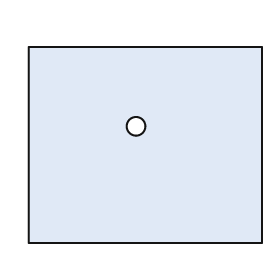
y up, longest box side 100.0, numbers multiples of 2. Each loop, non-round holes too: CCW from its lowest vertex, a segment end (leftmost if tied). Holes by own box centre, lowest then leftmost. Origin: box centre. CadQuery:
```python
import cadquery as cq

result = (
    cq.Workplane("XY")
    .moveTo(-50.0, -42.0)
    .lineTo(50.0, -42.0)
    .lineTo(50.0, 42.0)
    .lineTo(-50.0, 42.0)
    .close()
    .moveTo(-4.0, 8.0)
    .circle(4.0)
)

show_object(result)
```